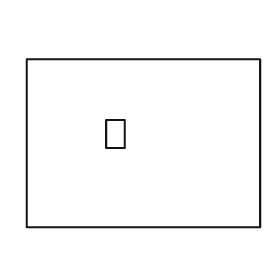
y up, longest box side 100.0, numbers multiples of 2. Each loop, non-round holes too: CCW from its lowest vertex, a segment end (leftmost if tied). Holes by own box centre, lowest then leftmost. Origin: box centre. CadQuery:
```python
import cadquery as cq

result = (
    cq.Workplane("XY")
    .moveTo(-50.0, -36.0)
    .lineTo(50.0, -36.0)
    .lineTo(50.0, 36.0)
    .lineTo(-50.0, 36.0)
    .close()
    .moveTo(-16.0, -2.0)
    .lineTo(-8.0, -2.0)
    .lineTo(-8.0, 10.0)
    .lineTo(-16.0, 10.0)
    .close()
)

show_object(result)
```